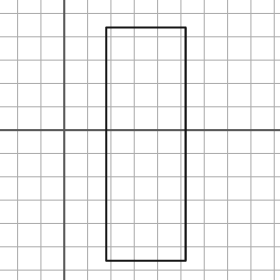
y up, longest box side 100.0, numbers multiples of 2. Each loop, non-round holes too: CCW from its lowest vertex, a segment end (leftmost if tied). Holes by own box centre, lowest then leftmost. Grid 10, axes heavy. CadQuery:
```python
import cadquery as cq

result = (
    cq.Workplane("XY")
    .moveTo(18.0, -56.0)
    .lineTo(52.0, -56.0)
    .lineTo(52.0, 44.0)
    .lineTo(18.0, 44.0)
    .close()
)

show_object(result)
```